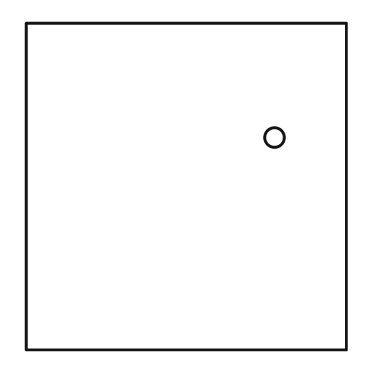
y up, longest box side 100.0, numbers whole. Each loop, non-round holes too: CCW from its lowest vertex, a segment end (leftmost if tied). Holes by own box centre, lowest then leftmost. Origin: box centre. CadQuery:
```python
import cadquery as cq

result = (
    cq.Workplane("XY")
    .moveTo(-49.0, -50.0)
    .lineTo(49.0, -50.0)
    .lineTo(49.0, 50.0)
    .lineTo(-49.0, 50.0)
    .close()
    .moveTo(27.0, 15.0)
    .circle(3.0)
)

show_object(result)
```